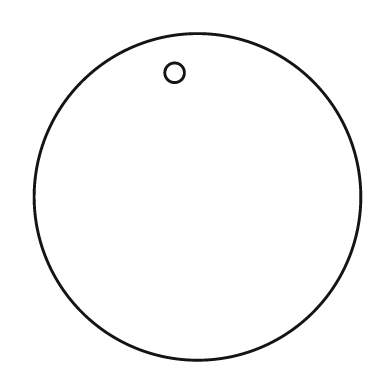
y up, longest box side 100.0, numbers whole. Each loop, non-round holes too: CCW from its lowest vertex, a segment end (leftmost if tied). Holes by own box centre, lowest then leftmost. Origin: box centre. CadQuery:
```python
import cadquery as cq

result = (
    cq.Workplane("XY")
    .moveTo(0.0, 0.0)
    .circle(50.0)
    .moveTo(-7.0, 38.0)
    .circle(3.0)
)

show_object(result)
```